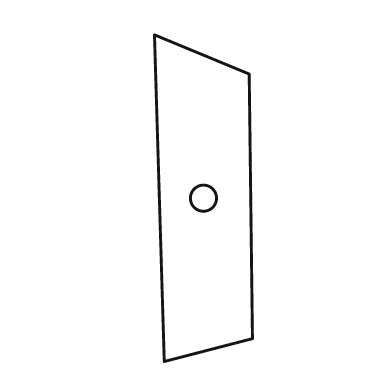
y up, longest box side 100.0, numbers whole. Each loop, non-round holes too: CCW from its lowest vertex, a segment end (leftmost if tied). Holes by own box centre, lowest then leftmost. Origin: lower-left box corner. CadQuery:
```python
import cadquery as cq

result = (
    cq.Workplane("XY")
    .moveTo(3.0, 0.0)
    .lineTo(30.0, 7.0)
    .lineTo(29.0, 88.0)
    .lineTo(0.0, 100.0)
    .close()
    .moveTo(15.0, 50.0)
    .circle(4.0)
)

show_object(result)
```